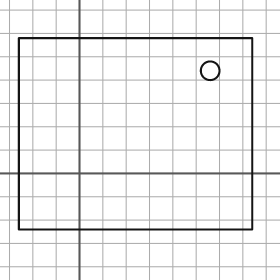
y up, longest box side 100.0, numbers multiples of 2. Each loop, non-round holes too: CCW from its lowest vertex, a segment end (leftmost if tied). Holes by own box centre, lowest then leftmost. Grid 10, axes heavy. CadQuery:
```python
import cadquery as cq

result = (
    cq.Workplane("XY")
    .moveTo(-26.0, -24.0)
    .lineTo(74.0, -24.0)
    .lineTo(74.0, 58.0)
    .lineTo(-26.0, 58.0)
    .close()
    .moveTo(56.0, 44.0)
    .circle(4.0)
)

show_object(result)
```